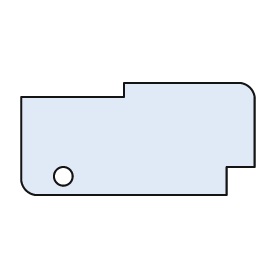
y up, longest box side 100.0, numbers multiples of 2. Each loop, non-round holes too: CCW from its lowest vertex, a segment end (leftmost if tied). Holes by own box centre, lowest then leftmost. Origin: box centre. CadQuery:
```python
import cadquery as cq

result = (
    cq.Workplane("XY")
    .moveTo(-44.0, -24.0)
    .lineTo(38.0, -24.0)
    .lineTo(38.0, -12.0)
    .lineTo(50.0, -12.0)
    .lineTo(50.0, 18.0)
    .threePointArc((48.0, 22.0), (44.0, 24.0))
    .lineTo(-6.0, 24.0)
    .lineTo(-6.0, 18.0)
    .lineTo(-50.0, 18.0)
    .lineTo(-50.0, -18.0)
    .threePointArc((-48.0, -22.0), (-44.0, -24.0))
    .close()
    .moveTo(-32.0, -16.0)
    .circle(4.0)
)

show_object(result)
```